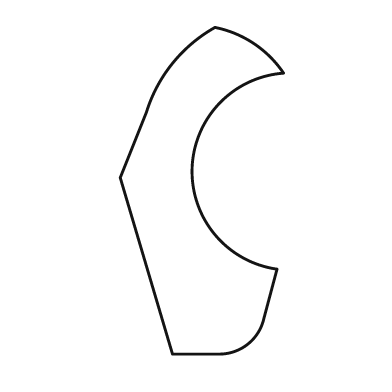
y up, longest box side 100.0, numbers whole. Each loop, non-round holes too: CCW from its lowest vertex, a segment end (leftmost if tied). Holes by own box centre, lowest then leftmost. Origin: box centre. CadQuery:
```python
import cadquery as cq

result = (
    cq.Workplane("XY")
    .moveTo(-9.0, -50.0)
    .lineTo(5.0, -50.0)
    .threePointArc((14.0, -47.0), (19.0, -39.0))
    .lineTo(23.0, -24.0)
    .threePointArc((-3.0, 7.0), (25.0, 36.0))
    .threePointArc((16.0, 45.0), (4.0, 50.0))
    .threePointArc((-9.0, 39.0), (-17.0, 24.0))
    .lineTo(-25.0, 4.0)
    .close()
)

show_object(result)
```